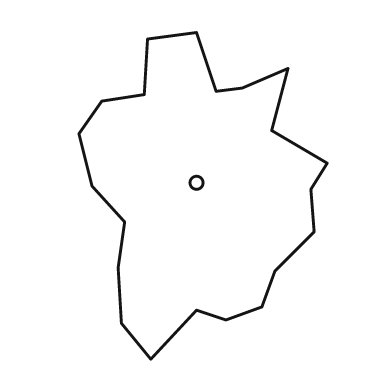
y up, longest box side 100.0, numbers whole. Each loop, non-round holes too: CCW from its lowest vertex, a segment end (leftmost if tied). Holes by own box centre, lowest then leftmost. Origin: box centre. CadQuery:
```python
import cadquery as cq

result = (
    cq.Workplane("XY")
    .moveTo(-16.0, -50.0)
    .lineTo(-2.0, -35.0)
    .lineTo(7.0, -38.0)
    .lineTo(18.0, -34.0)
    .lineTo(22.0, -23.0)
    .lineTo(34.0, -11.0)
    .lineTo(33.0, 2.0)
    .lineTo(38.0, 10.0)
    .lineTo(21.0, 20.0)
    .lineTo(26.0, 39.0)
    .lineTo(12.0, 33.0)
    .lineTo(4.0, 32.0)
    .lineTo(-2.0, 50.0)
    .lineTo(-17.0, 48.0)
    .lineTo(-18.0, 31.0)
    .lineTo(-31.0, 29.0)
    .lineTo(-38.0, 19.0)
    .lineTo(-34.0, 3.0)
    .lineTo(-24.0, -8.0)
    .lineTo(-26.0, -22.0)
    .lineTo(-25.0, -39.0)
    .close()
    .moveTo(-2.0, 4.0)
    .circle(2.0)
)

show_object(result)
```